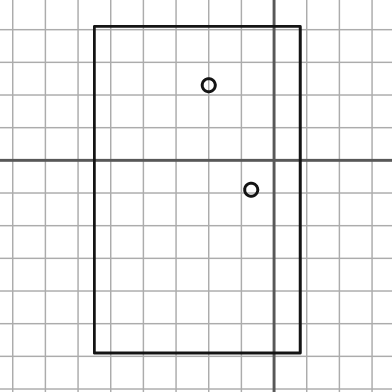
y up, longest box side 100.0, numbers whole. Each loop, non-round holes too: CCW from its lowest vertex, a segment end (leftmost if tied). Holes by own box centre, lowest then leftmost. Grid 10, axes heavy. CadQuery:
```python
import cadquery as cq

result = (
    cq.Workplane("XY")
    .moveTo(-55.0, -59.0)
    .lineTo(8.0, -59.0)
    .lineTo(8.0, 41.0)
    .lineTo(-55.0, 41.0)
    .close()
    .moveTo(-7.0, -9.0)
    .circle(2.0)
    .moveTo(-20.0, 23.0)
    .circle(2.0)
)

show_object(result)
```